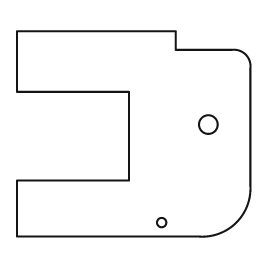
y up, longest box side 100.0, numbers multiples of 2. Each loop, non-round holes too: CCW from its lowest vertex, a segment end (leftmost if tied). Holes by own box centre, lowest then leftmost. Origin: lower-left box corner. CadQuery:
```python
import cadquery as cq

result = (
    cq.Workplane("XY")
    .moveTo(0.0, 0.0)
    .lineTo(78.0, 0.0)
    .threePointArc((94.0, 6.0), (100.0, 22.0))
    .lineTo(100.0, 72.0)
    .threePointArc((98.0, 78.0), (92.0, 80.0))
    .lineTo(68.0, 80.0)
    .lineTo(68.0, 88.0)
    .lineTo(0.0, 88.0)
    .lineTo(0.0, 62.0)
    .lineTo(48.0, 62.0)
    .lineTo(48.0, 24.0)
    .lineTo(0.0, 24.0)
    .close()
    .moveTo(62.0, 6.0)
    .circle(2.0)
    .moveTo(82.0, 48.0)
    .circle(4.0)
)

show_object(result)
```